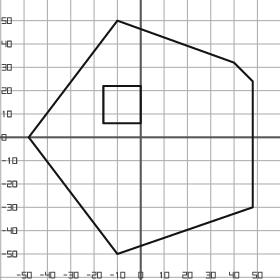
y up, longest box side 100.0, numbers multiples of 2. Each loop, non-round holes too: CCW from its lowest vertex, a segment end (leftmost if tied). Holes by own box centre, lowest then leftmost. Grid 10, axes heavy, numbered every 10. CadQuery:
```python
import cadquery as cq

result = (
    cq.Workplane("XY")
    .moveTo(-10.0, -50.0)
    .lineTo(48.0, -30.0)
    .lineTo(48.0, 24.0)
    .lineTo(40.0, 32.0)
    .lineTo(-10.0, 50.0)
    .lineTo(-48.0, 0.0)
    .close()
    .moveTo(-16.0, 6.0)
    .lineTo(0.0, 6.0)
    .lineTo(0.0, 22.0)
    .lineTo(-16.0, 22.0)
    .close()
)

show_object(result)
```